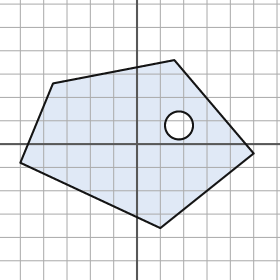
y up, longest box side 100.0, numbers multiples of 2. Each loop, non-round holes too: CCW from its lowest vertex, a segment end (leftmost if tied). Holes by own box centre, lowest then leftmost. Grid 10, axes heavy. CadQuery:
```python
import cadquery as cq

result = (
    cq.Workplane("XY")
    .moveTo(10.0, -36.0)
    .lineTo(50.0, -4.0)
    .lineTo(16.0, 36.0)
    .lineTo(-36.0, 26.0)
    .lineTo(-50.0, -8.0)
    .close()
    .moveTo(18.0, 8.0)
    .circle(6.0)
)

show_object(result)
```